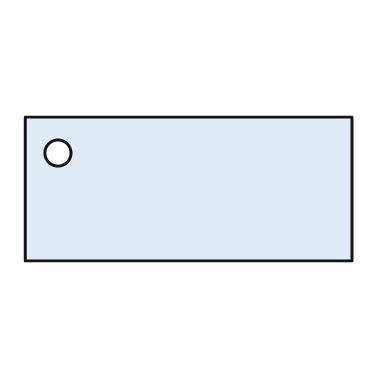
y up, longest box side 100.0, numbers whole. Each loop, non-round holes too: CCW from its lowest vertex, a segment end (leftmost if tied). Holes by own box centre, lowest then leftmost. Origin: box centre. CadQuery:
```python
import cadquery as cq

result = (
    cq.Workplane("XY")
    .moveTo(-50.0, -22.0)
    .lineTo(50.0, -22.0)
    .lineTo(50.0, 22.0)
    .lineTo(-50.0, 22.0)
    .close()
    .moveTo(-40.0, 11.0)
    .circle(4.0)
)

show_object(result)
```